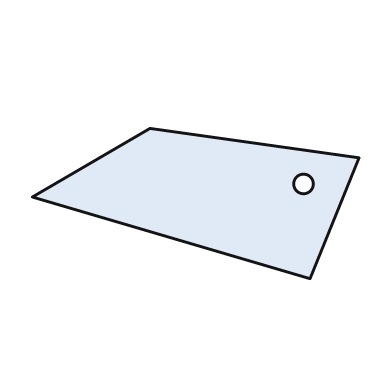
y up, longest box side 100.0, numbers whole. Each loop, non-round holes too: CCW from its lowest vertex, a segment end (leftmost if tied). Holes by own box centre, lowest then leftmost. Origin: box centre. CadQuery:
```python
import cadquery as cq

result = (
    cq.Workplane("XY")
    .moveTo(35.0, -23.0)
    .lineTo(50.0, 14.0)
    .lineTo(-14.0, 23.0)
    .lineTo(-50.0, 2.0)
    .close()
    .moveTo(33.0, 6.0)
    .circle(3.0)
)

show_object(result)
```